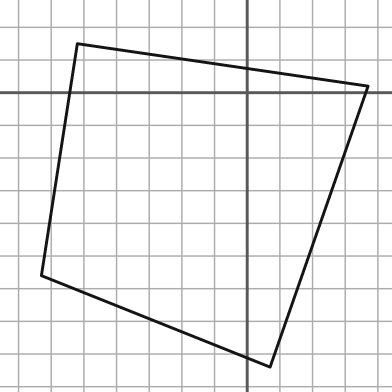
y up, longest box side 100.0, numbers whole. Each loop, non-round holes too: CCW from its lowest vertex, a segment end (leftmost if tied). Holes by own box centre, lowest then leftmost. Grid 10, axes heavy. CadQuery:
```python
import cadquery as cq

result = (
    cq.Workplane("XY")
    .moveTo(7.0, -84.0)
    .lineTo(37.0, 2.0)
    .lineTo(-52.0, 15.0)
    .lineTo(-63.0, -56.0)
    .close()
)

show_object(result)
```